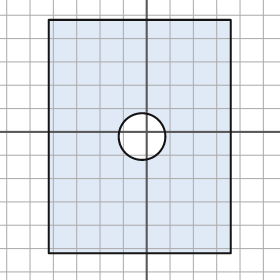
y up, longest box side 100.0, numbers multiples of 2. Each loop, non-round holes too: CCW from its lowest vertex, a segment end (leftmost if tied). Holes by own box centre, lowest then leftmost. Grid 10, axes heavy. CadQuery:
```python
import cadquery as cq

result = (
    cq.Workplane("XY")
    .moveTo(-42.0, -52.0)
    .lineTo(36.0, -52.0)
    .lineTo(36.0, 48.0)
    .lineTo(-42.0, 48.0)
    .close()
    .moveTo(-2.0, -2.0)
    .circle(10.0)
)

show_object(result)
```